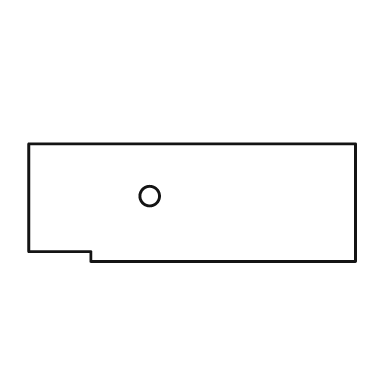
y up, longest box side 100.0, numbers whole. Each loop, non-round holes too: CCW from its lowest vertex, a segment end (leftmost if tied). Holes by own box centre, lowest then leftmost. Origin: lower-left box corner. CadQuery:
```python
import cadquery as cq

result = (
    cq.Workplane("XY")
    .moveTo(19.0, 0.0)
    .lineTo(100.0, 0.0)
    .lineTo(100.0, 36.0)
    .lineTo(0.0, 36.0)
    .lineTo(0.0, 3.0)
    .lineTo(19.0, 3.0)
    .close()
    .moveTo(37.0, 20.0)
    .circle(3.0)
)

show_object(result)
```